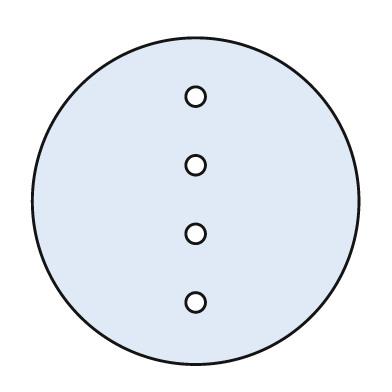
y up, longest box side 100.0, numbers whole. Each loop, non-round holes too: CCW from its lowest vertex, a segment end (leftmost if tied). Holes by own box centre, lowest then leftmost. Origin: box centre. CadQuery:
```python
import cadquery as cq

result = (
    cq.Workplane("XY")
    .moveTo(0.0, 0.0)
    .circle(50.0)
    .moveTo(0.0, -31.0)
    .circle(3.0)
    .moveTo(0.0, -10.0)
    .circle(3.0)
    .moveTo(0.0, 11.0)
    .circle(3.0)
    .moveTo(0.0, 32.0)
    .circle(3.0)
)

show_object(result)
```